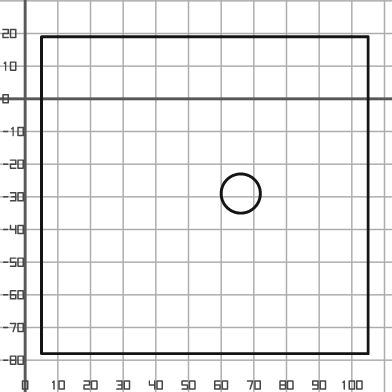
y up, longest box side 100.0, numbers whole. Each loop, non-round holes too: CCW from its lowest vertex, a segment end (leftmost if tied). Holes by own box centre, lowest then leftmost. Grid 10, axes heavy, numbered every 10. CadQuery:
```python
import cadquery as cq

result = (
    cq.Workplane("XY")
    .moveTo(5.0, -78.0)
    .lineTo(105.0, -78.0)
    .lineTo(105.0, 19.0)
    .lineTo(5.0, 19.0)
    .close()
    .moveTo(66.0, -29.0)
    .circle(6.0)
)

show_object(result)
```